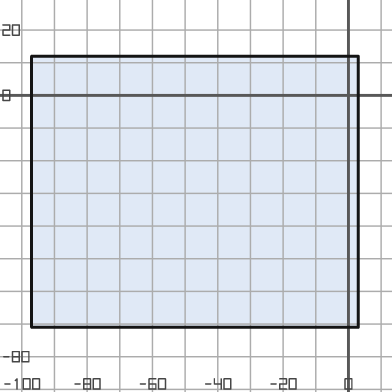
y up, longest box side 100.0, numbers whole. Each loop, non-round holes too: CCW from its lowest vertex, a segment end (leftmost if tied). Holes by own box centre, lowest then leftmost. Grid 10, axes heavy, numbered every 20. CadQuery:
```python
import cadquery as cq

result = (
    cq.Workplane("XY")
    .moveTo(-97.0, -71.0)
    .lineTo(3.0, -71.0)
    .lineTo(3.0, 12.0)
    .lineTo(-97.0, 12.0)
    .close()
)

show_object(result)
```